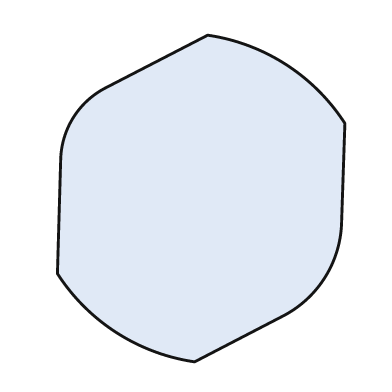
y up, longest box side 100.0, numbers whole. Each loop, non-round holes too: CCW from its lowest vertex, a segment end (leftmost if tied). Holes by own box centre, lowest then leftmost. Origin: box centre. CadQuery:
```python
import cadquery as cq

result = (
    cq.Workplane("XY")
    .moveTo(-2.0, -50.0)
    .lineTo(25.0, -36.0)
    .threePointArc((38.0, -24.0), (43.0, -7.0))
    .lineTo(44.0, 23.0)
    .threePointArc((26.0, 41.0), (2.0, 50.0))
    .lineTo(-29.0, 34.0)
    .threePointArc((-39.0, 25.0), (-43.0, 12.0))
    .lineTo(-44.0, -23.0)
    .threePointArc((-26.0, -41.0), (-2.0, -50.0))
    .close()
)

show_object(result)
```